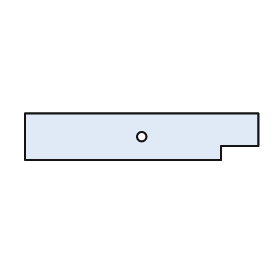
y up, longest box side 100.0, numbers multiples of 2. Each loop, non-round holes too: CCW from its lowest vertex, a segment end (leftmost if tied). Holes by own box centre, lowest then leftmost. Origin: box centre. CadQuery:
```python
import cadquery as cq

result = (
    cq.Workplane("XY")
    .moveTo(-50.0, -10.0)
    .lineTo(34.0, -10.0)
    .lineTo(34.0, -4.0)
    .lineTo(50.0, -4.0)
    .lineTo(50.0, 10.0)
    .lineTo(-50.0, 10.0)
    .close()
    .moveTo(0.0, 0.0)
    .circle(2.0)
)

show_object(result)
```